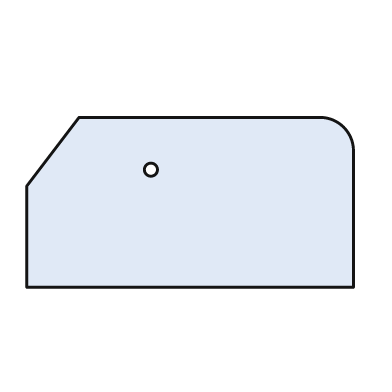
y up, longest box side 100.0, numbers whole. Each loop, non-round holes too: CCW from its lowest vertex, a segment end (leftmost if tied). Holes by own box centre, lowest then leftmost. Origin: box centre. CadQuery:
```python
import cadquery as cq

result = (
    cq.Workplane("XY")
    .moveTo(-50.0, -26.0)
    .lineTo(50.0, -26.0)
    .lineTo(50.0, 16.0)
    .threePointArc((47.0, 23.0), (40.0, 26.0))
    .lineTo(-34.0, 26.0)
    .lineTo(-50.0, 5.0)
    .close()
    .moveTo(-12.0, 10.0)
    .circle(2.0)
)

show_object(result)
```